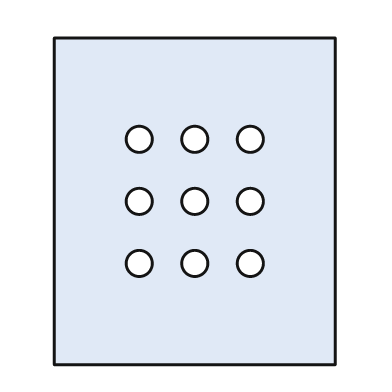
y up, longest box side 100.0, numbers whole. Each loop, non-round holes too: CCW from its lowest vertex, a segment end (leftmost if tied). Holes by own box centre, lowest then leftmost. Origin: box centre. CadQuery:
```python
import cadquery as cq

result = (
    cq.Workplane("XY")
    .moveTo(-43.0, -50.0)
    .lineTo(43.0, -50.0)
    .lineTo(43.0, 50.0)
    .lineTo(-43.0, 50.0)
    .close()
    .moveTo(-17.0, -19.0)
    .circle(4.0)
    .moveTo(0.0, -19.0)
    .circle(4.0)
    .moveTo(17.0, -19.0)
    .circle(4.0)
    .moveTo(-17.0, 0.0)
    .circle(4.0)
    .moveTo(0.0, 0.0)
    .circle(4.0)
    .moveTo(17.0, 0.0)
    .circle(4.0)
    .moveTo(-17.0, 19.0)
    .circle(4.0)
    .moveTo(0.0, 19.0)
    .circle(4.0)
    .moveTo(17.0, 19.0)
    .circle(4.0)
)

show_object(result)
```